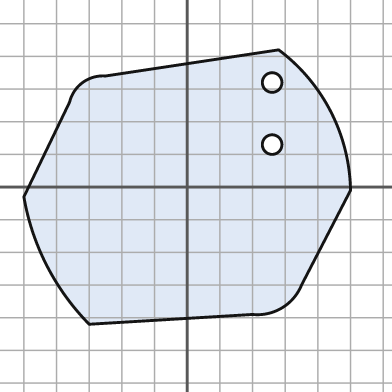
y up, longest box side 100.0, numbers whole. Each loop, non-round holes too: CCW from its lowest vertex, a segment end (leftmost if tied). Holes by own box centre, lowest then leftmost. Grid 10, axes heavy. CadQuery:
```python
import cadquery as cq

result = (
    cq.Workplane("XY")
    .moveTo(-30.0, -42.0)
    .lineTo(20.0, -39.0)
    .threePointArc((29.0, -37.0), (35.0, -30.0))
    .lineTo(50.0, -1.0)
    .threePointArc((44.0, 23.0), (28.0, 42.0))
    .lineTo(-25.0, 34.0)
    .threePointArc((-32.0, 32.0), (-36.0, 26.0))
    .lineTo(-50.0, -3.0)
    .threePointArc((-43.0, -24.0), (-30.0, -42.0))
    .close()
    .moveTo(26.0, 13.0)
    .circle(3.0)
    .moveTo(26.0, 32.0)
    .circle(3.0)
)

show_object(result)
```